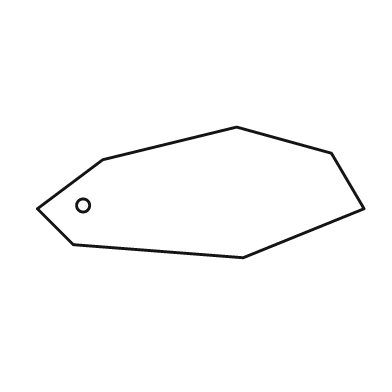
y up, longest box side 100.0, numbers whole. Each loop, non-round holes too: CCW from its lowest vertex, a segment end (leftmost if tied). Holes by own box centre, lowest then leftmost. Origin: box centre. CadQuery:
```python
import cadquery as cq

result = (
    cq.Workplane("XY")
    .moveTo(13.0, -20.0)
    .lineTo(50.0, -5.0)
    .lineTo(40.0, 12.0)
    .lineTo(11.0, 20.0)
    .lineTo(-30.0, 10.0)
    .lineTo(-50.0, -5.0)
    .lineTo(-39.0, -16.0)
    .close()
    .moveTo(-36.0, -4.0)
    .circle(2.0)
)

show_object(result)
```